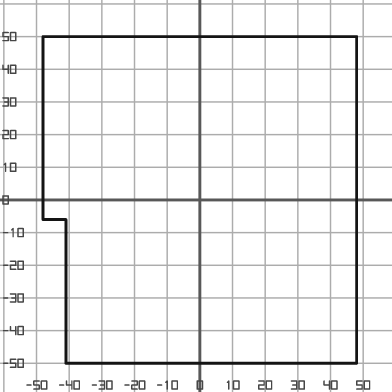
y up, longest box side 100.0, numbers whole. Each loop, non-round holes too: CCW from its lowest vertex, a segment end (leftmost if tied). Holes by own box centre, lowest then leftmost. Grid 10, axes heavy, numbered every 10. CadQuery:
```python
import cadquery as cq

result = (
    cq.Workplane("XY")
    .moveTo(-41.0, -50.0)
    .lineTo(48.0, -50.0)
    .lineTo(48.0, 50.0)
    .lineTo(-48.0, 50.0)
    .lineTo(-48.0, -6.0)
    .lineTo(-41.0, -6.0)
    .close()
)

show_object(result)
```